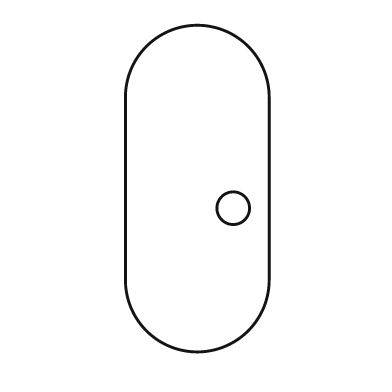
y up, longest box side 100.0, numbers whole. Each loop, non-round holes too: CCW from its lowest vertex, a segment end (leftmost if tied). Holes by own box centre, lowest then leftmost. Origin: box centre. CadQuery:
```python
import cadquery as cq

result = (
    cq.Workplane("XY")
    .moveTo(-22.0, -28.0)
    .threePointArc((0.0, -50.0), (22.0, -28.0))
    .lineTo(22.0, 28.0)
    .threePointArc((0.0, 50.0), (-22.0, 28.0))
    .close()
    .moveTo(11.0, -6.0)
    .circle(5.0)
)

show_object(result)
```